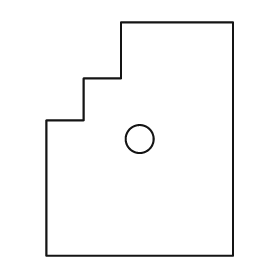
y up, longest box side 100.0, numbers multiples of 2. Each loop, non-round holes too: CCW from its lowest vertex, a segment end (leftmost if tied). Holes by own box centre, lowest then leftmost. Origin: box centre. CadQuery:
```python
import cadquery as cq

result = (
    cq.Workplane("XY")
    .moveTo(-40.0, -50.0)
    .lineTo(40.0, -50.0)
    .lineTo(40.0, 50.0)
    .lineTo(-8.0, 50.0)
    .lineTo(-8.0, 26.0)
    .lineTo(-24.0, 26.0)
    .lineTo(-24.0, 8.0)
    .lineTo(-40.0, 8.0)
    .close()
    .moveTo(0.0, 0.0)
    .circle(6.0)
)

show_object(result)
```